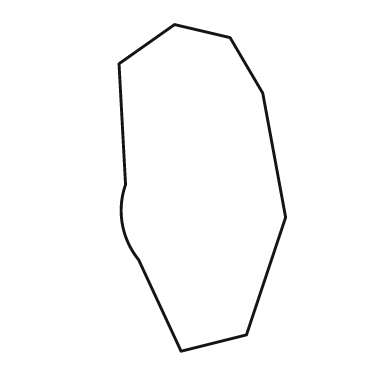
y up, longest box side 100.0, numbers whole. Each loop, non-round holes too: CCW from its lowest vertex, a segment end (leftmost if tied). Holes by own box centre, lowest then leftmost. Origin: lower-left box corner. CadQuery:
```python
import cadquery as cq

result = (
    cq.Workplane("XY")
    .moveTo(19.0, 0.0)
    .lineTo(39.0, 5.0)
    .lineTo(51.0, 41.0)
    .lineTo(44.0, 79.0)
    .lineTo(34.0, 96.0)
    .lineTo(17.0, 100.0)
    .lineTo(0.0, 88.0)
    .lineTo(2.0, 51.0)
    .threePointArc((1.0, 39.0), (6.0, 28.0))
    .close()
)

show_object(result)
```